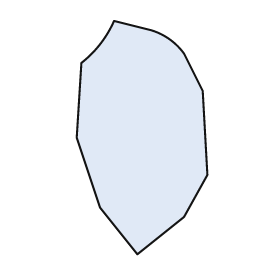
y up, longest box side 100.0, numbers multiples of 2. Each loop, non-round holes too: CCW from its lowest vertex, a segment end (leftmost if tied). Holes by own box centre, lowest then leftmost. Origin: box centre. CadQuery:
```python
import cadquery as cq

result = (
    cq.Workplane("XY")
    .moveTo(-2.0, -50.0)
    .lineTo(18.0, -34.0)
    .lineTo(28.0, -16.0)
    .lineTo(26.0, 20.0)
    .lineTo(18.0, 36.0)
    .threePointArc((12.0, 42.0), (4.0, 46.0))
    .lineTo(-12.0, 50.0)
    .threePointArc((-18.0, 40.0), (-26.0, 32.0))
    .lineTo(-28.0, 0.0)
    .lineTo(-18.0, -30.0)
    .close()
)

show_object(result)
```